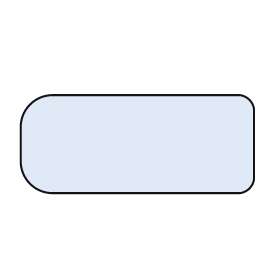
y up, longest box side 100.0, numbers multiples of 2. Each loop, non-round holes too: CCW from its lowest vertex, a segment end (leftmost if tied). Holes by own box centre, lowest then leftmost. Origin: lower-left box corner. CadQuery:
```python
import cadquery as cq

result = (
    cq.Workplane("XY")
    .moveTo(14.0, 0.0)
    .lineTo(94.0, 0.0)
    .threePointArc((98.0, 2.0), (100.0, 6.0))
    .lineTo(100.0, 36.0)
    .threePointArc((98.0, 40.0), (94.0, 42.0))
    .lineTo(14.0, 42.0)
    .threePointArc((4.0, 38.0), (0.0, 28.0))
    .lineTo(0.0, 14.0)
    .threePointArc((4.0, 4.0), (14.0, 0.0))
    .close()
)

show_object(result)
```